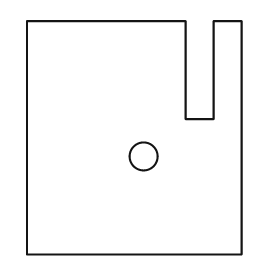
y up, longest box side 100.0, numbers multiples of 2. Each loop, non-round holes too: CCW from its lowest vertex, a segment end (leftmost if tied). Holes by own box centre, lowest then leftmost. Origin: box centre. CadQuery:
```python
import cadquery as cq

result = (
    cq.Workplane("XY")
    .moveTo(-46.0, -50.0)
    .lineTo(46.0, -50.0)
    .lineTo(46.0, 50.0)
    .lineTo(34.0, 50.0)
    .lineTo(34.0, 8.0)
    .lineTo(22.0, 8.0)
    .lineTo(22.0, 50.0)
    .lineTo(-46.0, 50.0)
    .close()
    .moveTo(4.0, -8.0)
    .circle(6.0)
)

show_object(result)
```